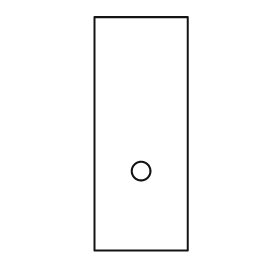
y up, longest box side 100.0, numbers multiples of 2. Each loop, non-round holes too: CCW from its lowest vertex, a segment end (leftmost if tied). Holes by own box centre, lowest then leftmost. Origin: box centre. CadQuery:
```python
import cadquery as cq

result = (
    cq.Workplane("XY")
    .moveTo(-20.0, -50.0)
    .lineTo(20.0, -50.0)
    .lineTo(20.0, 50.0)
    .lineTo(-20.0, 50.0)
    .close()
    .moveTo(0.0, -16.0)
    .circle(4.0)
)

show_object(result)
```